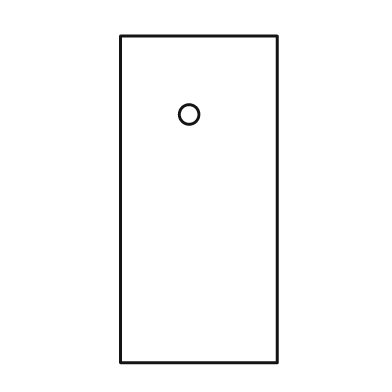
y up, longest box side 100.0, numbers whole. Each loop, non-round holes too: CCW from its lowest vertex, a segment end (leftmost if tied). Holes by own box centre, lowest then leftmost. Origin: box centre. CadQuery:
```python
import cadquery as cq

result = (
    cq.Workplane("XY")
    .moveTo(-24.0, -50.0)
    .lineTo(24.0, -50.0)
    .lineTo(24.0, 50.0)
    .lineTo(-24.0, 50.0)
    .close()
    .moveTo(-3.0, 26.0)
    .circle(3.0)
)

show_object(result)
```